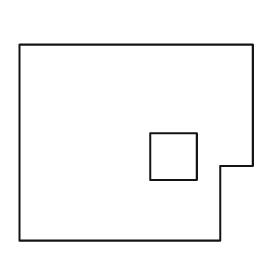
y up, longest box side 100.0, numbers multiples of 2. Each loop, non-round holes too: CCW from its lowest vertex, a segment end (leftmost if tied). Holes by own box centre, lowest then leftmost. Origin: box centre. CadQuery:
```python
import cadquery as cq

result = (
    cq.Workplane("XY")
    .moveTo(-50.0, -42.0)
    .lineTo(36.0, -42.0)
    .lineTo(36.0, -10.0)
    .lineTo(50.0, -10.0)
    .lineTo(50.0, 42.0)
    .lineTo(-50.0, 42.0)
    .close()
    .moveTo(6.0, -16.0)
    .lineTo(26.0, -16.0)
    .lineTo(26.0, 4.0)
    .lineTo(6.0, 4.0)
    .close()
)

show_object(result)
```